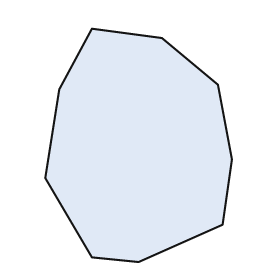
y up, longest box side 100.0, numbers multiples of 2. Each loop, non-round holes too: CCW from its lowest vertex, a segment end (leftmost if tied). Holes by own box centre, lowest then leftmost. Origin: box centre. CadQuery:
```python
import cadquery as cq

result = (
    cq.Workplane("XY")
    .moveTo(0.0, -50.0)
    .lineTo(36.0, -34.0)
    .lineTo(40.0, -6.0)
    .lineTo(34.0, 26.0)
    .lineTo(10.0, 46.0)
    .lineTo(-20.0, 50.0)
    .lineTo(-34.0, 24.0)
    .lineTo(-40.0, -14.0)
    .lineTo(-20.0, -48.0)
    .close()
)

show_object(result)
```